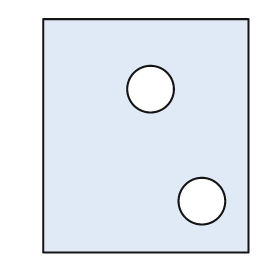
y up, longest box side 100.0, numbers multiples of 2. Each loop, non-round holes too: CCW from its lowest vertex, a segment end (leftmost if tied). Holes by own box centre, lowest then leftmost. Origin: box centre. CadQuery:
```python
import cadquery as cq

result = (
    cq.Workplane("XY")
    .moveTo(-44.0, -50.0)
    .lineTo(44.0, -50.0)
    .lineTo(44.0, 50.0)
    .lineTo(-44.0, 50.0)
    .close()
    .moveTo(24.0, -28.0)
    .circle(10.0)
    .moveTo(2.0, 20.0)
    .circle(10.0)
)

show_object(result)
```